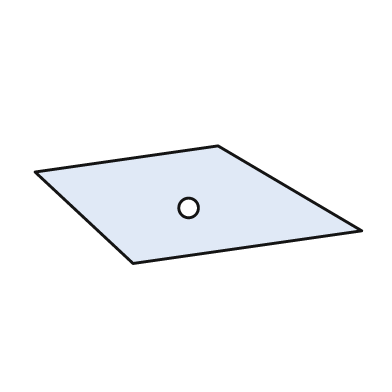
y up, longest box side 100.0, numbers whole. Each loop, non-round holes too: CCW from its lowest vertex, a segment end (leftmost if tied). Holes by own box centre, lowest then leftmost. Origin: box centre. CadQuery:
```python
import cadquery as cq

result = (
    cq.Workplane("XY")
    .moveTo(-20.0, -18.0)
    .lineTo(50.0, -8.0)
    .lineTo(6.0, 18.0)
    .lineTo(-50.0, 10.0)
    .close()
    .moveTo(-3.0, -1.0)
    .circle(3.0)
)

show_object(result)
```